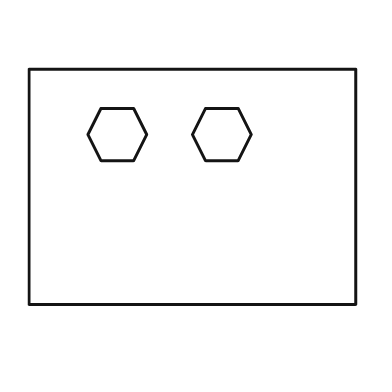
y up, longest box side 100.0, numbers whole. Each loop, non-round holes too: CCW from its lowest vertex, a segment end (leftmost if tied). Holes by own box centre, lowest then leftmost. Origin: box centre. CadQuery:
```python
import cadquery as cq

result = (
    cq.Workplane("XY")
    .moveTo(-50.0, -36.0)
    .lineTo(50.0, -36.0)
    .lineTo(50.0, 36.0)
    .lineTo(-50.0, 36.0)
    .close()
    .moveTo(-28.0, 8.0)
    .lineTo(-18.0, 8.0)
    .lineTo(-14.0, 16.0)
    .lineTo(-18.0, 24.0)
    .lineTo(-28.0, 24.0)
    .lineTo(-32.0, 16.0)
    .close()
    .moveTo(4.0, 8.0)
    .lineTo(14.0, 8.0)
    .lineTo(18.0, 16.0)
    .lineTo(14.0, 24.0)
    .lineTo(4.0, 24.0)
    .lineTo(0.0, 16.0)
    .close()
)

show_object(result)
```